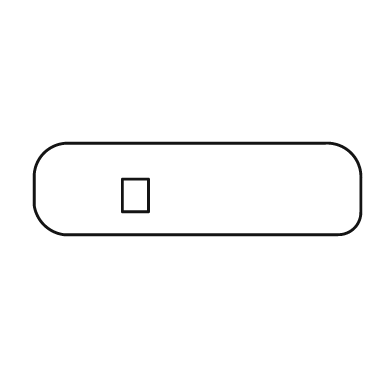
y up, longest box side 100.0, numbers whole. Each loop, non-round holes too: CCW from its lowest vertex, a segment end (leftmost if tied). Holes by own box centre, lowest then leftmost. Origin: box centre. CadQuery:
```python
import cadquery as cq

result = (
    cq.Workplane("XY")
    .moveTo(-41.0, -14.0)
    .lineTo(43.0, -14.0)
    .threePointArc((48.0, -12.0), (50.0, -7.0))
    .lineTo(50.0, 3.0)
    .threePointArc((47.0, 11.0), (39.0, 14.0))
    .lineTo(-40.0, 14.0)
    .threePointArc((-47.0, 11.0), (-50.0, 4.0))
    .lineTo(-50.0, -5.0)
    .threePointArc((-47.0, -11.0), (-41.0, -14.0))
    .close()
    .moveTo(-23.0, -7.0)
    .lineTo(-15.0, -7.0)
    .lineTo(-15.0, 3.0)
    .lineTo(-23.0, 3.0)
    .close()
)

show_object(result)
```